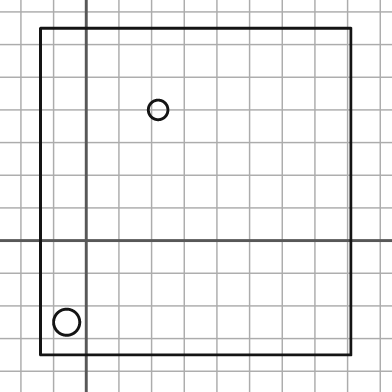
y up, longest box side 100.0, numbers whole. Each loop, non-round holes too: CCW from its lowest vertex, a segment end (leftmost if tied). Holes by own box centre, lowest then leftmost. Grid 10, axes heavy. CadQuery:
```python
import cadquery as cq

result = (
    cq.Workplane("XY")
    .moveTo(-14.0, -35.0)
    .lineTo(81.0, -35.0)
    .lineTo(81.0, 65.0)
    .lineTo(-14.0, 65.0)
    .close()
    .moveTo(-6.0, -25.0)
    .circle(4.0)
    .moveTo(22.0, 40.0)
    .circle(3.0)
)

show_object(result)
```